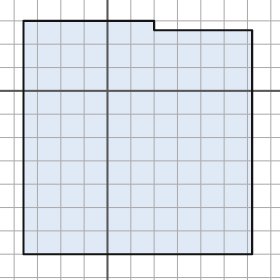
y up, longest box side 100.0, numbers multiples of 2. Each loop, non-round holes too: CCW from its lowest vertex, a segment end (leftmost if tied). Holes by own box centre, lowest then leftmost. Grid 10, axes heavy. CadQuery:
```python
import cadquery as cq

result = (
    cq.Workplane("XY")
    .moveTo(-36.0, -70.0)
    .lineTo(62.0, -70.0)
    .lineTo(62.0, 26.0)
    .lineTo(20.0, 26.0)
    .lineTo(20.0, 30.0)
    .lineTo(-36.0, 30.0)
    .close()
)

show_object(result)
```